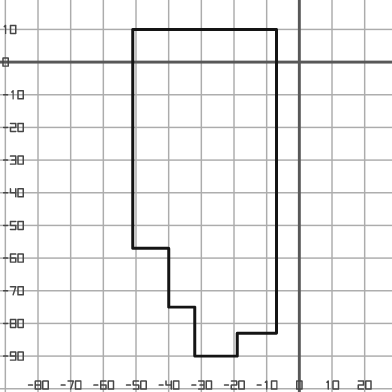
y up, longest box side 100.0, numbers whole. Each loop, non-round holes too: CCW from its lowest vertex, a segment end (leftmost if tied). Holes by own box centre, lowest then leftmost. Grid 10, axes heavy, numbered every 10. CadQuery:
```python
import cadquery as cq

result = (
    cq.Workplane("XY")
    .moveTo(-32.0, -90.0)
    .lineTo(-19.0, -90.0)
    .lineTo(-19.0, -83.0)
    .lineTo(-7.0, -83.0)
    .lineTo(-7.0, 10.0)
    .lineTo(-51.0, 10.0)
    .lineTo(-51.0, -57.0)
    .lineTo(-40.0, -57.0)
    .lineTo(-40.0, -75.0)
    .lineTo(-32.0, -75.0)
    .close()
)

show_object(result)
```